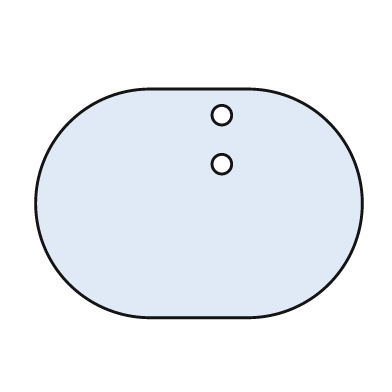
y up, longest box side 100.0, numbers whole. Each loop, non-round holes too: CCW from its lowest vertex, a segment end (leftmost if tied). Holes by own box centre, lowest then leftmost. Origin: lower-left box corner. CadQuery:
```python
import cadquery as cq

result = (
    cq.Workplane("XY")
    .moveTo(35.0, 0.0)
    .lineTo(65.0, 0.0)
    .threePointArc((100.0, 35.0), (65.0, 70.0))
    .lineTo(35.0, 70.0)
    .threePointArc((0.0, 35.0), (35.0, 0.0))
    .close()
    .moveTo(57.0, 47.0)
    .circle(3.0)
    .moveTo(57.0, 62.0)
    .circle(3.0)
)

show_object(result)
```